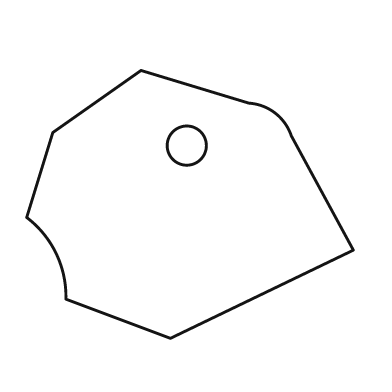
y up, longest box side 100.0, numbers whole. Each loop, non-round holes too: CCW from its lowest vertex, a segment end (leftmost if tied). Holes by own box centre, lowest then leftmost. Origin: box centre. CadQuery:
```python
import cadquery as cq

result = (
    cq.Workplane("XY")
    .moveTo(-6.0, -41.0)
    .lineTo(50.0, -14.0)
    .lineTo(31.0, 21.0)
    .threePointArc((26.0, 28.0), (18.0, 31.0))
    .lineTo(-15.0, 41.0)
    .lineTo(-42.0, 22.0)
    .lineTo(-50.0, -4.0)
    .threePointArc((-41.0, -15.0), (-38.0, -29.0))
    .close()
    .moveTo(-1.0, 18.0)
    .circle(6.0)
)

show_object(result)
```